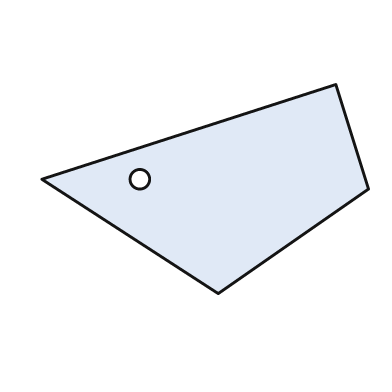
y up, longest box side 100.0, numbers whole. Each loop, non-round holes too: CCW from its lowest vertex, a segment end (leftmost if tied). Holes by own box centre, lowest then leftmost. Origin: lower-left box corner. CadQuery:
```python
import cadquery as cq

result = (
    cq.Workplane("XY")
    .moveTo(54.0, 0.0)
    .lineTo(100.0, 32.0)
    .lineTo(90.0, 64.0)
    .lineTo(0.0, 35.0)
    .close()
    .moveTo(30.0, 35.0)
    .circle(3.0)
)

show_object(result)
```